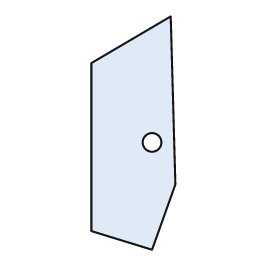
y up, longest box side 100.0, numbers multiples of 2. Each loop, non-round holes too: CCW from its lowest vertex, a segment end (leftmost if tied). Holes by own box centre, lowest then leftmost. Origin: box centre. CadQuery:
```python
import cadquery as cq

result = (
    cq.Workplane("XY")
    .moveTo(8.0, -50.0)
    .lineTo(18.0, -22.0)
    .lineTo(16.0, 50.0)
    .lineTo(-18.0, 30.0)
    .lineTo(-18.0, -42.0)
    .close()
    .moveTo(8.0, -4.0)
    .circle(4.0)
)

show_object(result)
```